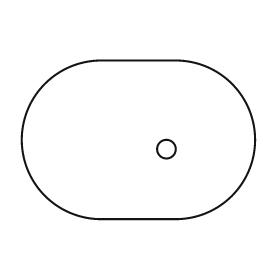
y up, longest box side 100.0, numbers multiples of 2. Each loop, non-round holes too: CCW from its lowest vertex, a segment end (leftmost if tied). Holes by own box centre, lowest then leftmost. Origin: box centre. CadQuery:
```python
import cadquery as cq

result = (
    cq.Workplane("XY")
    .moveTo(-16.0, -34.0)
    .lineTo(16.0, -34.0)
    .threePointArc((50.0, 0.0), (16.0, 34.0))
    .lineTo(-16.0, 34.0)
    .threePointArc((-50.0, 0.0), (-16.0, -34.0))
    .close()
    .moveTo(12.0, -4.0)
    .circle(4.0)
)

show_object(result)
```